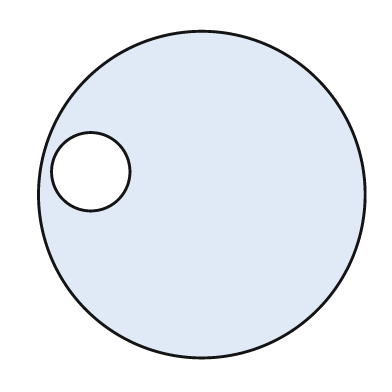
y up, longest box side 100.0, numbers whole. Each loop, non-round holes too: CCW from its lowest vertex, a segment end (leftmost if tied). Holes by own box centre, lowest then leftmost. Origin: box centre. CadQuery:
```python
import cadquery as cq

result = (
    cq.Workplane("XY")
    .moveTo(0.0, 0.0)
    .circle(50.0)
    .moveTo(-34.0, 7.0)
    .circle(12.0)
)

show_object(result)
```